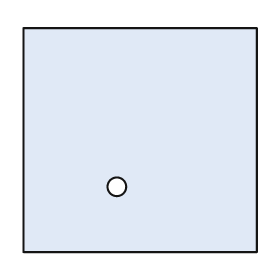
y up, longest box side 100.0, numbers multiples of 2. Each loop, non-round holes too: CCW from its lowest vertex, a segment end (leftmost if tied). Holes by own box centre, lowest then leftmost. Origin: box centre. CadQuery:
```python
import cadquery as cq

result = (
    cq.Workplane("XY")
    .moveTo(-50.0, -48.0)
    .lineTo(50.0, -48.0)
    .lineTo(50.0, 48.0)
    .lineTo(-50.0, 48.0)
    .close()
    .moveTo(-10.0, -20.0)
    .circle(4.0)
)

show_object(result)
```